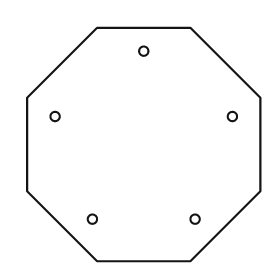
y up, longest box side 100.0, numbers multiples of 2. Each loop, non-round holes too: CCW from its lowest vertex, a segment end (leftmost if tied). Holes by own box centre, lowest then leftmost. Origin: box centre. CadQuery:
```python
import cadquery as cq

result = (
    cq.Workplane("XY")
    .moveTo(-20.0, -50.0)
    .lineTo(20.0, -50.0)
    .lineTo(50.0, -20.0)
    .lineTo(50.0, 20.0)
    .lineTo(20.0, 50.0)
    .lineTo(-20.0, 50.0)
    .lineTo(-50.0, 20.0)
    .lineTo(-50.0, -20.0)
    .close()
    .moveTo(-22.0, -32.0)
    .circle(2.0)
    .moveTo(22.0, -32.0)
    .circle(2.0)
    .moveTo(-38.0, 12.0)
    .circle(2.0)
    .moveTo(38.0, 12.0)
    .circle(2.0)
    .moveTo(0.0, 40.0)
    .circle(2.0)
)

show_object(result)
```